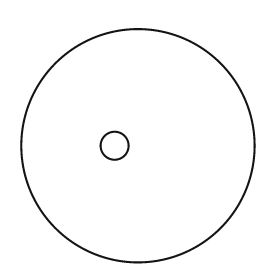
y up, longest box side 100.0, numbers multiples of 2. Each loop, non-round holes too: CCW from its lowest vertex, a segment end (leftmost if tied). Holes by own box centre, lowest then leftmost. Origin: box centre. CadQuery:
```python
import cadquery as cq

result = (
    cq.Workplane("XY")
    .moveTo(0.0, 0.0)
    .circle(50.0)
    .moveTo(-10.0, 0.0)
    .circle(6.0)
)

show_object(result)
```